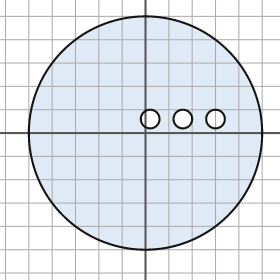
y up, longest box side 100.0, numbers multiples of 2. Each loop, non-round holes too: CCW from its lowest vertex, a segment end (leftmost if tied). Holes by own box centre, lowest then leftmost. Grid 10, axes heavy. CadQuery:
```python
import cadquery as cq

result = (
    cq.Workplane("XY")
    .moveTo(0.0, 0.0)
    .circle(50.0)
    .moveTo(2.0, 6.0)
    .circle(4.0)
    .moveTo(16.0, 6.0)
    .circle(4.0)
    .moveTo(30.0, 6.0)
    .circle(4.0)
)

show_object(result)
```